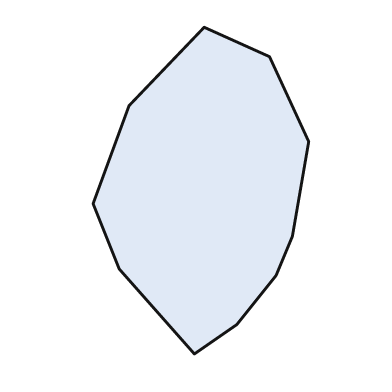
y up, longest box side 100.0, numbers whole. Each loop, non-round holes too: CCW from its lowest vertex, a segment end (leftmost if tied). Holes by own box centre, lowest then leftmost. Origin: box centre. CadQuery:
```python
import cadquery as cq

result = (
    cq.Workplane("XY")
    .moveTo(-2.0, -50.0)
    .lineTo(11.0, -41.0)
    .lineTo(23.0, -26.0)
    .lineTo(28.0, -14.0)
    .lineTo(33.0, 15.0)
    .lineTo(21.0, 41.0)
    .lineTo(1.0, 50.0)
    .lineTo(-22.0, 26.0)
    .lineTo(-33.0, -4.0)
    .lineTo(-25.0, -24.0)
    .close()
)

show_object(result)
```